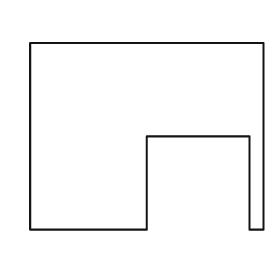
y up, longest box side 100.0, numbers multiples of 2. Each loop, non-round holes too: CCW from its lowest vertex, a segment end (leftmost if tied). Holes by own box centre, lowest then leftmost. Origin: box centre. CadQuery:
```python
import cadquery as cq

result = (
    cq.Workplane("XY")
    .moveTo(-50.0, -40.0)
    .lineTo(0.0, -40.0)
    .lineTo(0.0, 0.0)
    .lineTo(44.0, 0.0)
    .lineTo(44.0, -40.0)
    .lineTo(50.0, -40.0)
    .lineTo(50.0, 40.0)
    .lineTo(-50.0, 40.0)
    .close()
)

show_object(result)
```